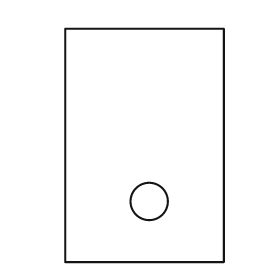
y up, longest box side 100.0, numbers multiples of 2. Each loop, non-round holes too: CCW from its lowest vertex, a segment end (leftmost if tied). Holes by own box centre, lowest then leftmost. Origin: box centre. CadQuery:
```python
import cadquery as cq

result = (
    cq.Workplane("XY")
    .moveTo(-34.0, -50.0)
    .lineTo(34.0, -50.0)
    .lineTo(34.0, 50.0)
    .lineTo(-34.0, 50.0)
    .close()
    .moveTo(2.0, -24.0)
    .circle(8.0)
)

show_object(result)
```